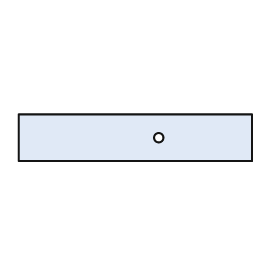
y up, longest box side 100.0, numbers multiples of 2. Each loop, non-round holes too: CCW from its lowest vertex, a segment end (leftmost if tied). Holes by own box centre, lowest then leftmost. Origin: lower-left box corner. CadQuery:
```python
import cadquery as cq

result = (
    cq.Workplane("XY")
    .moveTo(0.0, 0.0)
    .lineTo(100.0, 0.0)
    .lineTo(100.0, 20.0)
    .lineTo(0.0, 20.0)
    .close()
    .moveTo(60.0, 10.0)
    .circle(2.0)
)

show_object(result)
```